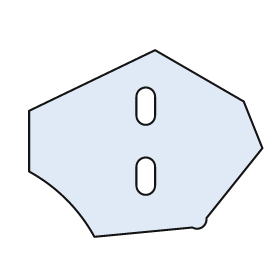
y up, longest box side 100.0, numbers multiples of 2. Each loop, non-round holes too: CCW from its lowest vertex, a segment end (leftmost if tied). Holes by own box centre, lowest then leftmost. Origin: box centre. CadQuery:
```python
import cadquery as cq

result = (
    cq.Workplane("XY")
    .moveTo(-22.0, -40.0)
    .lineTo(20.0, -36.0)
    .threePointArc((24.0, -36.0), (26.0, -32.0))
    .lineTo(50.0, -2.0)
    .lineTo(42.0, 18.0)
    .lineTo(4.0, 40.0)
    .lineTo(-50.0, 14.0)
    .lineTo(-50.0, -12.0)
    .threePointArc((-34.0, -24.0), (-22.0, -40.0))
    .close()
    .moveTo(-4.0, -18.0)
    .threePointArc((0.0, -22.0), (4.0, -18.0))
    .lineTo(4.0, -10.0)
    .threePointArc((0.0, -6.0), (-4.0, -10.0))
    .close()
    .moveTo(-4.0, 12.0)
    .threePointArc((0.0, 8.0), (4.0, 12.0))
    .lineTo(4.0, 20.0)
    .threePointArc((0.0, 24.0), (-4.0, 20.0))
    .close()
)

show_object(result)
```